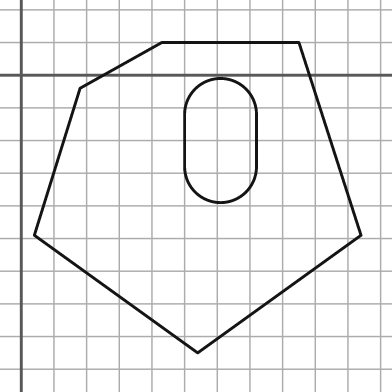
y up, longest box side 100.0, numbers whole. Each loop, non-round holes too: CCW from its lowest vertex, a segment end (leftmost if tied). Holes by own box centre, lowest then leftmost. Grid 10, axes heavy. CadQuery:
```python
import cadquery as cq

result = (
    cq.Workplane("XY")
    .moveTo(54.0, -85.0)
    .lineTo(104.0, -49.0)
    .lineTo(85.0, 10.0)
    .lineTo(43.0, 10.0)
    .lineTo(18.0, -4.0)
    .lineTo(4.0, -49.0)
    .close()
    .moveTo(50.0, -28.0)
    .threePointArc((61.0, -39.0), (72.0, -28.0))
    .lineTo(72.0, -12.0)
    .threePointArc((61.0, -1.0), (50.0, -12.0))
    .close()
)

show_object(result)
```